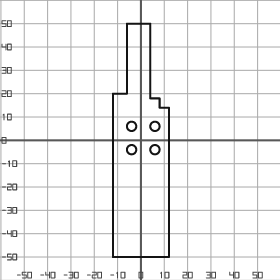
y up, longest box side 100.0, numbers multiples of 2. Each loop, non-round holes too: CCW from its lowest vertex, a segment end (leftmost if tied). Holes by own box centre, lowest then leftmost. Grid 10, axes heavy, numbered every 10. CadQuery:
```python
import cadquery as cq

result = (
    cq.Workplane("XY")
    .moveTo(-12.0, -50.0)
    .lineTo(12.0, -50.0)
    .lineTo(12.0, 14.0)
    .lineTo(8.0, 14.0)
    .lineTo(8.0, 18.0)
    .lineTo(4.0, 18.0)
    .lineTo(4.0, 50.0)
    .lineTo(-6.0, 50.0)
    .lineTo(-6.0, 20.0)
    .lineTo(-12.0, 20.0)
    .close()
    .moveTo(-4.0, -4.0)
    .circle(2.0)
    .moveTo(6.0, -4.0)
    .circle(2.0)
    .moveTo(-4.0, 6.0)
    .circle(2.0)
    .moveTo(6.0, 6.0)
    .circle(2.0)
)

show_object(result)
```